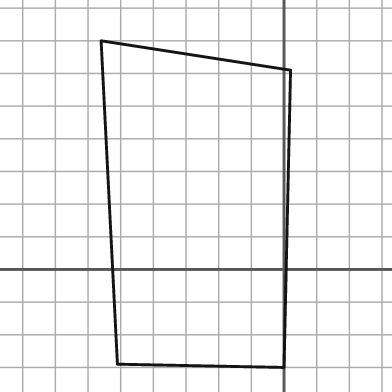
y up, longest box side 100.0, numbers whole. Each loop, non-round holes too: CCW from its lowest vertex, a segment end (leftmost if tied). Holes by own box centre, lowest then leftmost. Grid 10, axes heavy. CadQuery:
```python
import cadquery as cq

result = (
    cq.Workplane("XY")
    .moveTo(0.0, -30.0)
    .lineTo(2.0, 61.0)
    .lineTo(-56.0, 70.0)
    .lineTo(-51.0, -29.0)
    .close()
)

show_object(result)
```